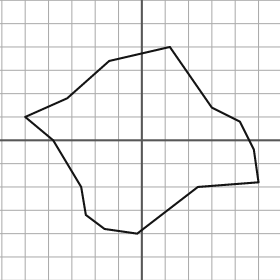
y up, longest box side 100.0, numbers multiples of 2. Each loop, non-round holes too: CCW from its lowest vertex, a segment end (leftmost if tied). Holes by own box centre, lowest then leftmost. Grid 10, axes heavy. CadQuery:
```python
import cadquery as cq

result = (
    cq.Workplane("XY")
    .moveTo(-2.0, -40.0)
    .lineTo(24.0, -20.0)
    .lineTo(50.0, -18.0)
    .lineTo(48.0, -4.0)
    .lineTo(42.0, 8.0)
    .lineTo(30.0, 14.0)
    .lineTo(12.0, 40.0)
    .lineTo(-14.0, 34.0)
    .lineTo(-32.0, 18.0)
    .lineTo(-50.0, 10.0)
    .lineTo(-38.0, 0.0)
    .lineTo(-26.0, -20.0)
    .lineTo(-24.0, -32.0)
    .lineTo(-16.0, -38.0)
    .close()
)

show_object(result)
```